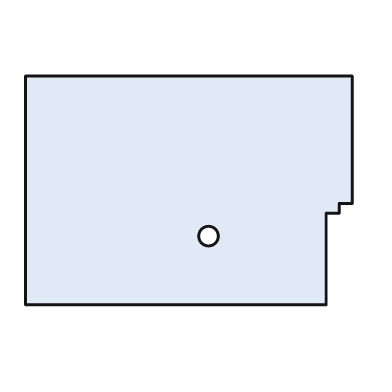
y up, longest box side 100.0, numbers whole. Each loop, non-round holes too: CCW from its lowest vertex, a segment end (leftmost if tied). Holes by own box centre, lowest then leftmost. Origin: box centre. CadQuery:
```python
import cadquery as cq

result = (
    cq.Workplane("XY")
    .moveTo(-50.0, -35.0)
    .lineTo(42.0, -35.0)
    .lineTo(42.0, -7.0)
    .lineTo(46.0, -7.0)
    .lineTo(46.0, -4.0)
    .lineTo(50.0, -4.0)
    .lineTo(50.0, 35.0)
    .lineTo(-50.0, 35.0)
    .close()
    .moveTo(6.0, -14.0)
    .circle(3.0)
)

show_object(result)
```